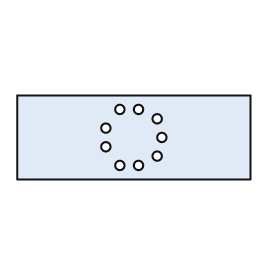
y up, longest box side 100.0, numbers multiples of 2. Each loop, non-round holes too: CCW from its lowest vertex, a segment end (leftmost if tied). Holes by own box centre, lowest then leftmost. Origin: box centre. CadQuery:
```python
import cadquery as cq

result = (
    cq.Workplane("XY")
    .moveTo(-50.0, -18.0)
    .lineTo(50.0, -18.0)
    .lineTo(50.0, 18.0)
    .lineTo(-50.0, 18.0)
    .close()
    .moveTo(-6.0, -12.0)
    .circle(2.0)
    .moveTo(2.0, -12.0)
    .circle(2.0)
    .moveTo(10.0, -8.0)
    .circle(2.0)
    .moveTo(-12.0, -4.0)
    .circle(2.0)
    .moveTo(12.0, 0.0)
    .circle(2.0)
    .moveTo(-12.0, 4.0)
    .circle(2.0)
    .moveTo(10.0, 8.0)
    .circle(2.0)
    .moveTo(-6.0, 12.0)
    .circle(2.0)
    .moveTo(2.0, 12.0)
    .circle(2.0)
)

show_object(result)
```